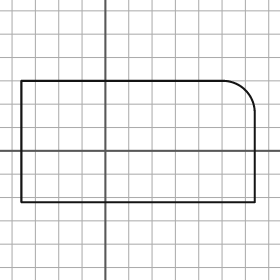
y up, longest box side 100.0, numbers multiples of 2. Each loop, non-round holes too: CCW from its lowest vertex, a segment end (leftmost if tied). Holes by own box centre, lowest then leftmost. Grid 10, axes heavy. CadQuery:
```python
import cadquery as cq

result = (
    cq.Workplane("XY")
    .moveTo(-36.0, -22.0)
    .lineTo(64.0, -22.0)
    .lineTo(64.0, 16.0)
    .threePointArc((60.0, 26.0), (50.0, 30.0))
    .lineTo(-36.0, 30.0)
    .close()
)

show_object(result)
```